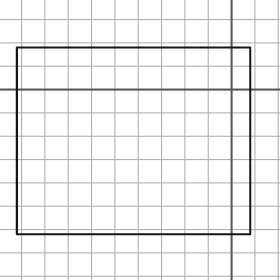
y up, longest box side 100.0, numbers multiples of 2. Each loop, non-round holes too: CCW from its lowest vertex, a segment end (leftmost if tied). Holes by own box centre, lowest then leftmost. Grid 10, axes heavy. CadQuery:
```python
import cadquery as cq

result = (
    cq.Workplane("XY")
    .moveTo(-92.0, -62.0)
    .lineTo(8.0, -62.0)
    .lineTo(8.0, 18.0)
    .lineTo(-92.0, 18.0)
    .close()
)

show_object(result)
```